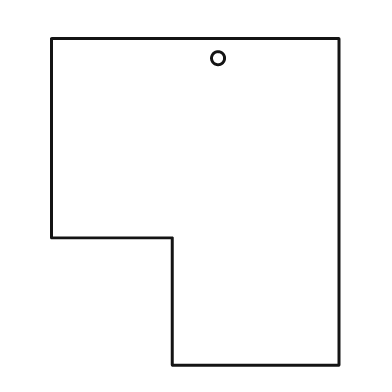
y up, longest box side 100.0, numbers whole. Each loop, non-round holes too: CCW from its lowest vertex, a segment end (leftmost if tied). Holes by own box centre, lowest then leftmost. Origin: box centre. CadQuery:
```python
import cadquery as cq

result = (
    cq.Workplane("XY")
    .moveTo(-7.0, -50.0)
    .lineTo(44.0, -50.0)
    .lineTo(44.0, 50.0)
    .lineTo(-44.0, 50.0)
    .lineTo(-44.0, -11.0)
    .lineTo(-7.0, -11.0)
    .close()
    .moveTo(7.0, 44.0)
    .circle(2.0)
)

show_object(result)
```